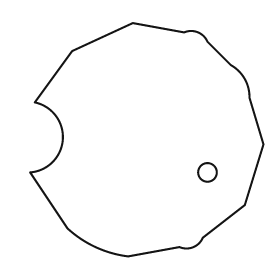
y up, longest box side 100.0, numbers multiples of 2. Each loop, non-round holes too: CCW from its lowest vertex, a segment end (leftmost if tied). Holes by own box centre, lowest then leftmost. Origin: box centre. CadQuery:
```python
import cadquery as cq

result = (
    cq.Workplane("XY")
    .moveTo(-8.0, -50.0)
    .lineTo(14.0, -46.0)
    .threePointArc((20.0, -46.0), (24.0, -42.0))
    .lineTo(42.0, -28.0)
    .lineTo(50.0, -2.0)
    .lineTo(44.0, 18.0)
    .threePointArc((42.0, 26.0), (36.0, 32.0))
    .lineTo(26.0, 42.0)
    .threePointArc((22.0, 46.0), (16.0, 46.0))
    .lineTo(-6.0, 50.0)
    .lineTo(-32.0, 38.0)
    .lineTo(-48.0, 16.0)
    .threePointArc((-36.0, 0.0), (-50.0, -14.0))
    .lineTo(-34.0, -38.0)
    .threePointArc((-22.0, -46.0), (-8.0, -50.0))
    .close()
    .moveTo(26.0, -14.0)
    .circle(4.0)
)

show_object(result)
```